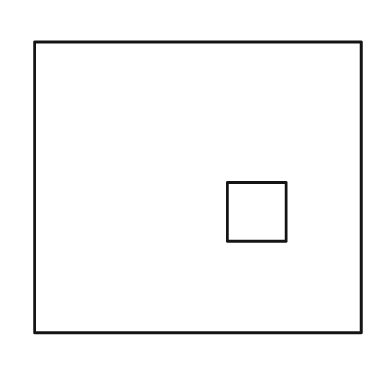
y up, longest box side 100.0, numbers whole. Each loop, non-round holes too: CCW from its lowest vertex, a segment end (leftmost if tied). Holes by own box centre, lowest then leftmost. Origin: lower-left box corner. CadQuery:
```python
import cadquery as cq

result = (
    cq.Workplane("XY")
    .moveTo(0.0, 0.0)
    .lineTo(100.0, 0.0)
    .lineTo(100.0, 89.0)
    .lineTo(0.0, 89.0)
    .close()
    .moveTo(59.0, 28.0)
    .lineTo(77.0, 28.0)
    .lineTo(77.0, 46.0)
    .lineTo(59.0, 46.0)
    .close()
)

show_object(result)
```